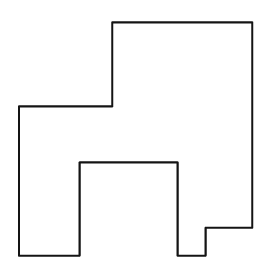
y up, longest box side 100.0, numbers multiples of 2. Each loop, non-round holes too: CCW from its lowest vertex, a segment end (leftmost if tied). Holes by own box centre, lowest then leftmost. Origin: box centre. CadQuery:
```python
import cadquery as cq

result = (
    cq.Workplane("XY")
    .moveTo(-50.0, -50.0)
    .lineTo(-24.0, -50.0)
    .lineTo(-24.0, -10.0)
    .lineTo(18.0, -10.0)
    .lineTo(18.0, -50.0)
    .lineTo(30.0, -50.0)
    .lineTo(30.0, -38.0)
    .lineTo(50.0, -38.0)
    .lineTo(50.0, 50.0)
    .lineTo(-10.0, 50.0)
    .lineTo(-10.0, 14.0)
    .lineTo(-50.0, 14.0)
    .close()
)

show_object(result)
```